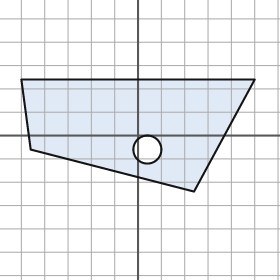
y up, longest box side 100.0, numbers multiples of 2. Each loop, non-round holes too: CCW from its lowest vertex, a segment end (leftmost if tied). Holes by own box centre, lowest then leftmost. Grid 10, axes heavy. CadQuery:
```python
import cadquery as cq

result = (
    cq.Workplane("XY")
    .moveTo(24.0, -24.0)
    .lineTo(50.0, 24.0)
    .lineTo(-50.0, 24.0)
    .lineTo(-46.0, -6.0)
    .close()
    .moveTo(4.0, -6.0)
    .circle(6.0)
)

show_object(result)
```